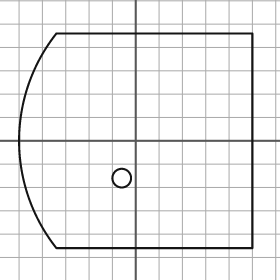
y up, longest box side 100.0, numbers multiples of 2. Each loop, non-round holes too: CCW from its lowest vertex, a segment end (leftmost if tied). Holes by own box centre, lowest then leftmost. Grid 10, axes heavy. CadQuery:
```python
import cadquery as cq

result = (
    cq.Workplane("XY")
    .moveTo(-34.0, -46.0)
    .lineTo(50.0, -46.0)
    .lineTo(50.0, 46.0)
    .lineTo(-34.0, 46.0)
    .threePointArc((-50.0, 0.0), (-34.0, -46.0))
    .close()
    .moveTo(-6.0, -16.0)
    .circle(4.0)
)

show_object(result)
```